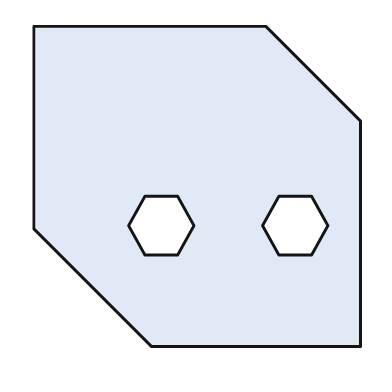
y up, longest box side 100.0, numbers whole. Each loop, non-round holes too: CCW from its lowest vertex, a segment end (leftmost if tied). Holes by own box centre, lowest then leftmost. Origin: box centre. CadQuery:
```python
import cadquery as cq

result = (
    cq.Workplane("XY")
    .moveTo(-14.0, -49.0)
    .lineTo(50.0, -49.0)
    .lineTo(50.0, 20.0)
    .lineTo(21.0, 49.0)
    .lineTo(-50.0, 49.0)
    .lineTo(-50.0, -13.0)
    .close()
    .moveTo(-16.0, -21.0)
    .lineTo(-6.0, -21.0)
    .lineTo(-1.0, -12.0)
    .lineTo(-6.0, -3.0)
    .lineTo(-16.0, -3.0)
    .lineTo(-21.0, -12.0)
    .close()
    .moveTo(25.0, -21.0)
    .lineTo(35.0, -21.0)
    .lineTo(40.0, -12.0)
    .lineTo(35.0, -3.0)
    .lineTo(25.0, -3.0)
    .lineTo(20.0, -12.0)
    .close()
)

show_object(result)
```